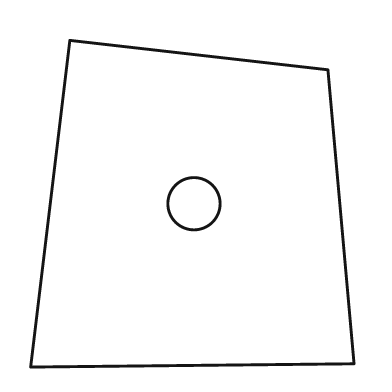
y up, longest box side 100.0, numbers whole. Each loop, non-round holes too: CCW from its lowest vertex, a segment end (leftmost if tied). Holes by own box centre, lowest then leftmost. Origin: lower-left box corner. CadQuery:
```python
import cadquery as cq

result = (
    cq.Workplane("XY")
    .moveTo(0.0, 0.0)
    .lineTo(99.0, 1.0)
    .lineTo(91.0, 91.0)
    .lineTo(12.0, 100.0)
    .close()
    .moveTo(50.0, 50.0)
    .circle(8.0)
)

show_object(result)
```